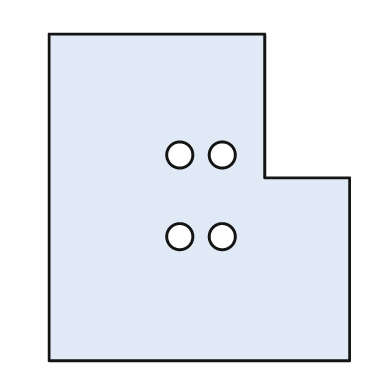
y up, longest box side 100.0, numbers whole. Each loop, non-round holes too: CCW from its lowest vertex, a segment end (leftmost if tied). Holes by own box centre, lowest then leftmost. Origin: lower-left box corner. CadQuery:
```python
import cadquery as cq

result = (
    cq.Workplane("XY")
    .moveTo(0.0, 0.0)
    .lineTo(92.0, 0.0)
    .lineTo(92.0, 56.0)
    .lineTo(66.0, 56.0)
    .lineTo(66.0, 100.0)
    .lineTo(0.0, 100.0)
    .close()
    .moveTo(40.0, 38.0)
    .circle(4.0)
    .moveTo(53.0, 38.0)
    .circle(4.0)
    .moveTo(40.0, 63.0)
    .circle(4.0)
    .moveTo(53.0, 63.0)
    .circle(4.0)
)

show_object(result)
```